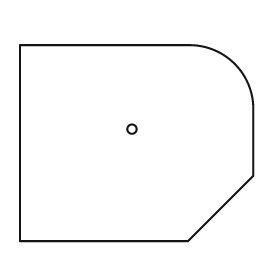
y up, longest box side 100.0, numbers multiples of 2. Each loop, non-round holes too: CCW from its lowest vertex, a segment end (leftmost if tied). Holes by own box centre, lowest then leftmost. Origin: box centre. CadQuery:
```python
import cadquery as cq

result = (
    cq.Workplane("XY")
    .moveTo(-50.0, -42.0)
    .lineTo(22.0, -42.0)
    .lineTo(50.0, -14.0)
    .lineTo(50.0, 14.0)
    .threePointArc((42.0, 34.0), (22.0, 42.0))
    .lineTo(-50.0, 42.0)
    .close()
    .moveTo(-2.0, 6.0)
    .circle(2.0)
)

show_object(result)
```